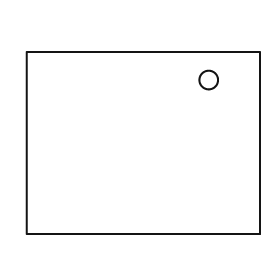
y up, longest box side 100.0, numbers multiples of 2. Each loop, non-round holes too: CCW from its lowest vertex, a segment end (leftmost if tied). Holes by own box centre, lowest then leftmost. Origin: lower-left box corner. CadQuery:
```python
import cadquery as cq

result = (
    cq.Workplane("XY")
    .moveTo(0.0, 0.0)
    .lineTo(100.0, 0.0)
    .lineTo(100.0, 78.0)
    .lineTo(0.0, 78.0)
    .close()
    .moveTo(78.0, 66.0)
    .circle(4.0)
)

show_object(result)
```